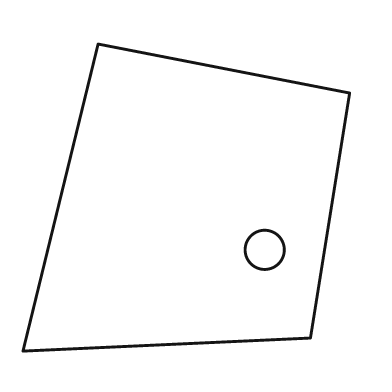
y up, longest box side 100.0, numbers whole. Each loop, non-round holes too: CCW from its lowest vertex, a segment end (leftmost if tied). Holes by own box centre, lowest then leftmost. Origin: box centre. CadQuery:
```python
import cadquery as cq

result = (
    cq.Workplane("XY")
    .moveTo(-50.0, -47.0)
    .lineTo(38.0, -43.0)
    .lineTo(50.0, 32.0)
    .lineTo(-27.0, 47.0)
    .close()
    .moveTo(24.0, -16.0)
    .circle(6.0)
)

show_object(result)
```